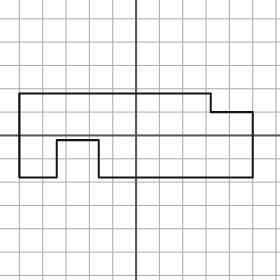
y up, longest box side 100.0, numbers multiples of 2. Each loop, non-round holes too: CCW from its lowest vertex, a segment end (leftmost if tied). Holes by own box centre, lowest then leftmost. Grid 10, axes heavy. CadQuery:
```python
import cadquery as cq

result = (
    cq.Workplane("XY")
    .moveTo(-50.0, -18.0)
    .lineTo(-34.0, -18.0)
    .lineTo(-34.0, -2.0)
    .lineTo(-16.0, -2.0)
    .lineTo(-16.0, -18.0)
    .lineTo(50.0, -18.0)
    .lineTo(50.0, 10.0)
    .lineTo(32.0, 10.0)
    .lineTo(32.0, 18.0)
    .lineTo(-50.0, 18.0)
    .close()
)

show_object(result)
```